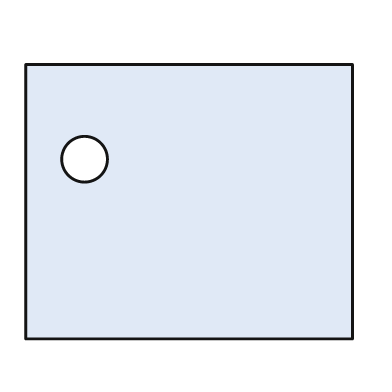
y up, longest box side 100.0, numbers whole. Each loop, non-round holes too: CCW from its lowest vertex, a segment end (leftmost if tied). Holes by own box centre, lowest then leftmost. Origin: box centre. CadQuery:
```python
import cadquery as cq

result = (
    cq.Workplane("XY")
    .moveTo(-50.0, -42.0)
    .lineTo(50.0, -42.0)
    .lineTo(50.0, 42.0)
    .lineTo(-50.0, 42.0)
    .close()
    .moveTo(-32.0, 13.0)
    .circle(7.0)
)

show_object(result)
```